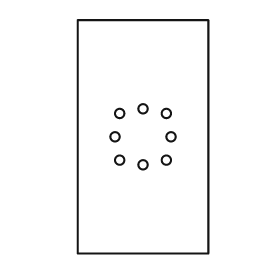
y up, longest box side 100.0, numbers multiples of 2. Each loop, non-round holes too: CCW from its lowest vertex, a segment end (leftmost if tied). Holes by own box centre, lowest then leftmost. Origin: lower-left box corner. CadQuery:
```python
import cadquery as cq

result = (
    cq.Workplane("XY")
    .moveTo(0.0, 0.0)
    .lineTo(56.0, 0.0)
    .lineTo(56.0, 100.0)
    .lineTo(0.0, 100.0)
    .close()
    .moveTo(28.0, 38.0)
    .circle(2.0)
    .moveTo(18.0, 40.0)
    .circle(2.0)
    .moveTo(38.0, 40.0)
    .circle(2.0)
    .moveTo(16.0, 50.0)
    .circle(2.0)
    .moveTo(40.0, 50.0)
    .circle(2.0)
    .moveTo(18.0, 60.0)
    .circle(2.0)
    .moveTo(38.0, 60.0)
    .circle(2.0)
    .moveTo(28.0, 62.0)
    .circle(2.0)
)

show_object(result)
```